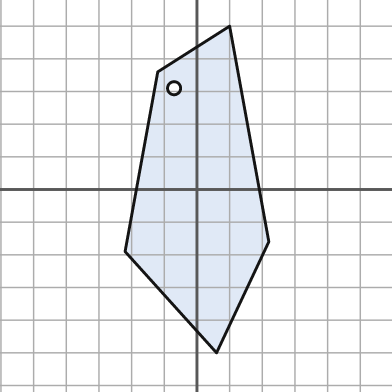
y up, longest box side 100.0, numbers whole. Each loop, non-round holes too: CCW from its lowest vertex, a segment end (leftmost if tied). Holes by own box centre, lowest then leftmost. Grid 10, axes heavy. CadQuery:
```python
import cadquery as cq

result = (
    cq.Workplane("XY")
    .moveTo(6.0, -50.0)
    .lineTo(22.0, -16.0)
    .lineTo(10.0, 50.0)
    .lineTo(-12.0, 36.0)
    .lineTo(-22.0, -19.0)
    .close()
    .moveTo(-7.0, 31.0)
    .circle(2.0)
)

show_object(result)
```